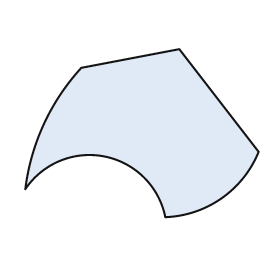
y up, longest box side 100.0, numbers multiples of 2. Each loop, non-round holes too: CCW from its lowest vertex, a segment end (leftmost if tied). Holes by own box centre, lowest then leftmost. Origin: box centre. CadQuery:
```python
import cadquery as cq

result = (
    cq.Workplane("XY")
    .moveTo(10.0, -36.0)
    .threePointArc((34.0, -28.0), (50.0, -8.0))
    .lineTo(16.0, 36.0)
    .lineTo(-26.0, 28.0)
    .threePointArc((-42.0, 4.0), (-50.0, -24.0))
    .threePointArc((-16.0, -10.0), (10.0, -36.0))
    .close()
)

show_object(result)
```